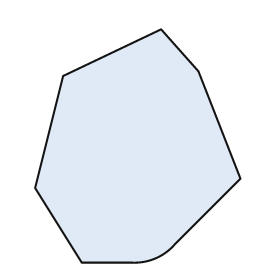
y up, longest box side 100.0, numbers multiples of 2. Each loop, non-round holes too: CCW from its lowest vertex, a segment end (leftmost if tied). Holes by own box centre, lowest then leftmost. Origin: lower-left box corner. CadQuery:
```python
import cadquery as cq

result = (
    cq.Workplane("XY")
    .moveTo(20.0, 0.0)
    .lineTo(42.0, 0.0)
    .threePointArc((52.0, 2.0), (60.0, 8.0))
    .lineTo(88.0, 36.0)
    .lineTo(70.0, 82.0)
    .lineTo(54.0, 100.0)
    .lineTo(12.0, 80.0)
    .lineTo(0.0, 32.0)
    .close()
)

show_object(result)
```